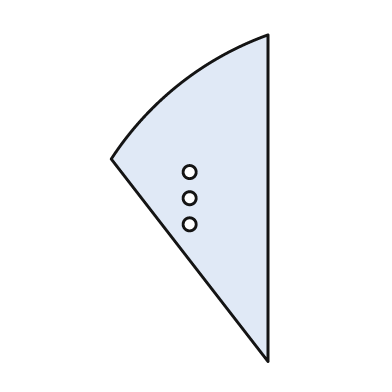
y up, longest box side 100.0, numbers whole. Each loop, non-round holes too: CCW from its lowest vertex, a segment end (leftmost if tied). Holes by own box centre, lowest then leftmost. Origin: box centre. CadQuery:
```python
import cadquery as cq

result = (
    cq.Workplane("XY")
    .moveTo(24.0, -50.0)
    .lineTo(24.0, 50.0)
    .threePointArc((-3.0, 35.0), (-24.0, 12.0))
    .close()
    .moveTo(0.0, -8.0)
    .circle(2.0)
    .moveTo(0.0, 0.0)
    .circle(2.0)
    .moveTo(0.0, 8.0)
    .circle(2.0)
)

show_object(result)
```